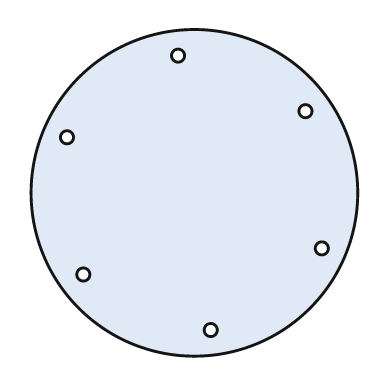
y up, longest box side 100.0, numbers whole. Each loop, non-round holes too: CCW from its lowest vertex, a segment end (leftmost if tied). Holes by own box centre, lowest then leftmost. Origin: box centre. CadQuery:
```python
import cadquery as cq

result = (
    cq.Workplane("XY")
    .moveTo(0.0, 0.0)
    .circle(50.0)
    .moveTo(5.0, -42.0)
    .circle(2.0)
    .moveTo(-34.0, -25.0)
    .circle(2.0)
    .moveTo(39.0, -17.0)
    .circle(2.0)
    .moveTo(-39.0, 17.0)
    .circle(2.0)
    .moveTo(34.0, 25.0)
    .circle(2.0)
    .moveTo(-5.0, 42.0)
    .circle(2.0)
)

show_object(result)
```